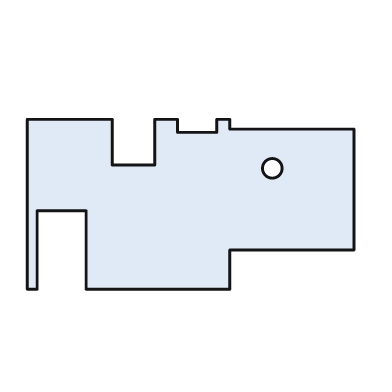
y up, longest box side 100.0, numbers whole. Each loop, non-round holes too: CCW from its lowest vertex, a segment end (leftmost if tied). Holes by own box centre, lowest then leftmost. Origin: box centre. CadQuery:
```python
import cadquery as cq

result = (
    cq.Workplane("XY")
    .moveTo(-50.0, -26.0)
    .lineTo(-47.0, -26.0)
    .lineTo(-47.0, -2.0)
    .lineTo(-32.0, -2.0)
    .lineTo(-32.0, -26.0)
    .lineTo(12.0, -26.0)
    .lineTo(12.0, -14.0)
    .lineTo(50.0, -14.0)
    .lineTo(50.0, 23.0)
    .lineTo(12.0, 23.0)
    .lineTo(12.0, 26.0)
    .lineTo(8.0, 26.0)
    .lineTo(8.0, 22.0)
    .lineTo(-4.0, 22.0)
    .lineTo(-4.0, 26.0)
    .lineTo(-11.0, 26.0)
    .lineTo(-11.0, 12.0)
    .lineTo(-24.0, 12.0)
    .lineTo(-24.0, 26.0)
    .lineTo(-50.0, 26.0)
    .close()
    .moveTo(25.0, 11.0)
    .circle(3.0)
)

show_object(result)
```